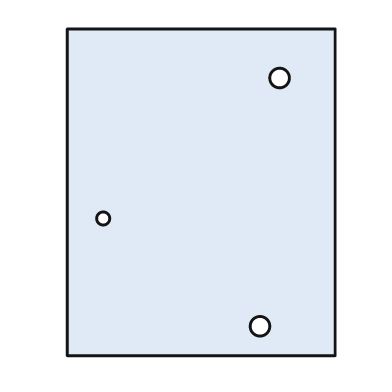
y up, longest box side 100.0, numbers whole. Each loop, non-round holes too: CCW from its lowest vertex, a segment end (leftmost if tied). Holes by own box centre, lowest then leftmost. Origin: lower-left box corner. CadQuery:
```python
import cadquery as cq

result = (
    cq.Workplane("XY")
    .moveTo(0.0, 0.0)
    .lineTo(82.0, 0.0)
    .lineTo(82.0, 100.0)
    .lineTo(0.0, 100.0)
    .close()
    .moveTo(59.0, 9.0)
    .circle(3.0)
    .moveTo(11.0, 42.0)
    .circle(2.0)
    .moveTo(65.0, 85.0)
    .circle(3.0)
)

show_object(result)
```